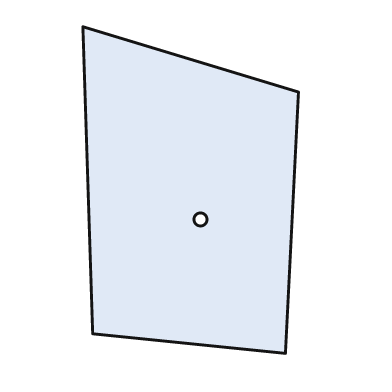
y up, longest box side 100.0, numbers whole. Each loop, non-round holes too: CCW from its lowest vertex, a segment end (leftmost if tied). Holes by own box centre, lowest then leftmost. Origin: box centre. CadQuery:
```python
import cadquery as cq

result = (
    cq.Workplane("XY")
    .moveTo(29.0, -50.0)
    .lineTo(33.0, 30.0)
    .lineTo(-33.0, 50.0)
    .lineTo(-30.0, -44.0)
    .close()
    .moveTo(3.0, -9.0)
    .circle(2.0)
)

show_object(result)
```